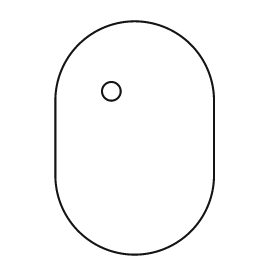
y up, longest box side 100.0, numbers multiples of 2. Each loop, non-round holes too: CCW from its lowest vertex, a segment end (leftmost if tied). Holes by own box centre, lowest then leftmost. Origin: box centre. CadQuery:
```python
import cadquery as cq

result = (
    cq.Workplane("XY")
    .moveTo(-34.0, -16.0)
    .threePointArc((0.0, -50.0), (34.0, -16.0))
    .lineTo(34.0, 16.0)
    .threePointArc((0.0, 50.0), (-34.0, 16.0))
    .close()
    .moveTo(-10.0, 20.0)
    .circle(4.0)
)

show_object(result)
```